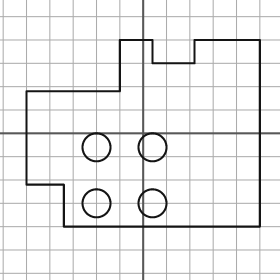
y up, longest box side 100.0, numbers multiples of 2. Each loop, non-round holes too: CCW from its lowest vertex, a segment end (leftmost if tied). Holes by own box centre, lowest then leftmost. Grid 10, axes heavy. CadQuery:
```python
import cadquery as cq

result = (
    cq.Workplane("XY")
    .moveTo(-34.0, -40.0)
    .lineTo(50.0, -40.0)
    .lineTo(50.0, 40.0)
    .lineTo(22.0, 40.0)
    .lineTo(22.0, 30.0)
    .lineTo(4.0, 30.0)
    .lineTo(4.0, 40.0)
    .lineTo(-10.0, 40.0)
    .lineTo(-10.0, 18.0)
    .lineTo(-50.0, 18.0)
    .lineTo(-50.0, -22.0)
    .lineTo(-34.0, -22.0)
    .close()
    .moveTo(-20.0, -30.0)
    .circle(6.0)
    .moveTo(4.0, -30.0)
    .circle(6.0)
    .moveTo(-20.0, -6.0)
    .circle(6.0)
    .moveTo(4.0, -6.0)
    .circle(6.0)
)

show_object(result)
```